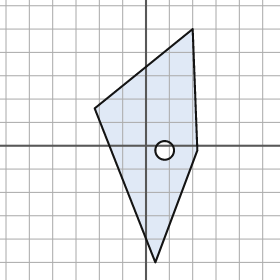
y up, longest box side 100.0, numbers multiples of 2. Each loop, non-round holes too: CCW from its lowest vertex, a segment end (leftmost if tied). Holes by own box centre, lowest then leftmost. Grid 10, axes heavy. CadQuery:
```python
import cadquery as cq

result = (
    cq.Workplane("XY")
    .moveTo(4.0, -50.0)
    .lineTo(22.0, -2.0)
    .lineTo(20.0, 50.0)
    .lineTo(-22.0, 16.0)
    .close()
    .moveTo(8.0, -2.0)
    .circle(4.0)
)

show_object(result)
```